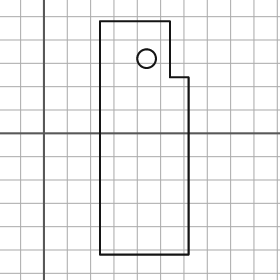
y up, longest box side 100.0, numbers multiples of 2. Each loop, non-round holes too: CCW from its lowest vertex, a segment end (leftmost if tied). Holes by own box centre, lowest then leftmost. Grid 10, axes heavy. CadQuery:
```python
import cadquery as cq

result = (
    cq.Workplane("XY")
    .moveTo(24.0, -52.0)
    .lineTo(62.0, -52.0)
    .lineTo(62.0, 24.0)
    .lineTo(54.0, 24.0)
    .lineTo(54.0, 48.0)
    .lineTo(24.0, 48.0)
    .close()
    .moveTo(44.0, 32.0)
    .circle(4.0)
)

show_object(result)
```